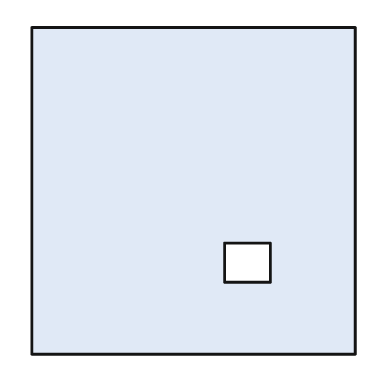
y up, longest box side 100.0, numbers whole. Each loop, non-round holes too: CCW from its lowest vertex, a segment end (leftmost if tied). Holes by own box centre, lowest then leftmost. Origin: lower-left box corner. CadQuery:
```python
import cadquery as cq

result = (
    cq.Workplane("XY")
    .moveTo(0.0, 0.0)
    .lineTo(99.0, 0.0)
    .lineTo(99.0, 100.0)
    .lineTo(0.0, 100.0)
    .close()
    .moveTo(59.0, 22.0)
    .lineTo(73.0, 22.0)
    .lineTo(73.0, 34.0)
    .lineTo(59.0, 34.0)
    .close()
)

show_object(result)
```